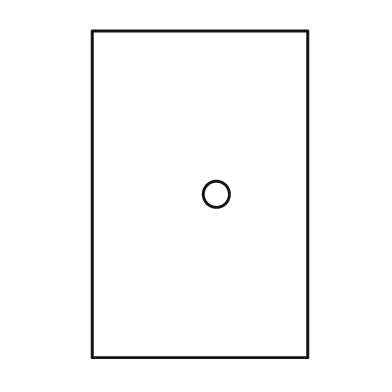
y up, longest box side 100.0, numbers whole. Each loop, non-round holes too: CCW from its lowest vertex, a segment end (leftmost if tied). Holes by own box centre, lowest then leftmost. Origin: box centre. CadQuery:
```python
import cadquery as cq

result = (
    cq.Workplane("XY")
    .moveTo(-33.0, -50.0)
    .lineTo(33.0, -50.0)
    .lineTo(33.0, 50.0)
    .lineTo(-33.0, 50.0)
    .close()
    .moveTo(5.0, 0.0)
    .circle(4.0)
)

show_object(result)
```